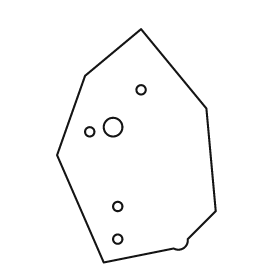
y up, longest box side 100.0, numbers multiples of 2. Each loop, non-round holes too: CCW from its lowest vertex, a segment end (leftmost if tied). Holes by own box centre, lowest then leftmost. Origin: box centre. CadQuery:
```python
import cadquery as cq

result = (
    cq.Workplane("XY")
    .moveTo(-14.0, -50.0)
    .lineTo(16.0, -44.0)
    .threePointArc((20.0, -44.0), (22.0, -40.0))
    .lineTo(34.0, -28.0)
    .lineTo(30.0, 16.0)
    .lineTo(2.0, 50.0)
    .lineTo(-22.0, 30.0)
    .lineTo(-34.0, -4.0)
    .close()
    .moveTo(-8.0, -40.0)
    .circle(2.0)
    .moveTo(-8.0, -26.0)
    .circle(2.0)
    .moveTo(-20.0, 6.0)
    .circle(2.0)
    .moveTo(-10.0, 8.0)
    .circle(4.0)
    .moveTo(2.0, 24.0)
    .circle(2.0)
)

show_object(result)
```